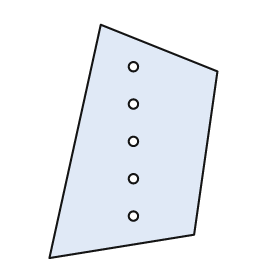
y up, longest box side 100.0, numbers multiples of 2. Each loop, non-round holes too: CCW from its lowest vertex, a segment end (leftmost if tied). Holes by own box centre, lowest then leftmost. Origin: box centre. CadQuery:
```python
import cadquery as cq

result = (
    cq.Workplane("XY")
    .moveTo(-36.0, -50.0)
    .lineTo(26.0, -40.0)
    .lineTo(36.0, 30.0)
    .lineTo(-14.0, 50.0)
    .close()
    .moveTo(0.0, -32.0)
    .circle(2.0)
    .moveTo(0.0, -16.0)
    .circle(2.0)
    .moveTo(0.0, 0.0)
    .circle(2.0)
    .moveTo(0.0, 16.0)
    .circle(2.0)
    .moveTo(0.0, 32.0)
    .circle(2.0)
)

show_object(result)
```